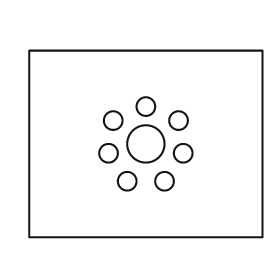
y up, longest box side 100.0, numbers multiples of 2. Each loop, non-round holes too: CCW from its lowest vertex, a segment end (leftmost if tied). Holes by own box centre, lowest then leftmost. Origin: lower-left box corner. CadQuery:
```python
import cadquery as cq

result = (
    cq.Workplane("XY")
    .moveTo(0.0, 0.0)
    .lineTo(100.0, 0.0)
    .lineTo(100.0, 80.0)
    .lineTo(0.0, 80.0)
    .close()
    .moveTo(42.0, 24.0)
    .circle(4.0)
    .moveTo(58.0, 24.0)
    .circle(4.0)
    .moveTo(34.0, 36.0)
    .circle(4.0)
    .moveTo(66.0, 36.0)
    .circle(4.0)
    .moveTo(50.0, 40.0)
    .circle(8.0)
    .moveTo(36.0, 50.0)
    .circle(4.0)
    .moveTo(64.0, 50.0)
    .circle(4.0)
    .moveTo(50.0, 56.0)
    .circle(4.0)
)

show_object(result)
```